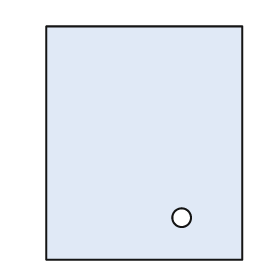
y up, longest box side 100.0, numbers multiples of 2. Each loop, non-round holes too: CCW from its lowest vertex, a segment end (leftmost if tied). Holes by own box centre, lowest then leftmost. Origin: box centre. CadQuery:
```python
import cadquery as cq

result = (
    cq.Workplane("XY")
    .moveTo(-42.0, -50.0)
    .lineTo(42.0, -50.0)
    .lineTo(42.0, 50.0)
    .lineTo(-42.0, 50.0)
    .close()
    .moveTo(16.0, -32.0)
    .circle(4.0)
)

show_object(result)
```